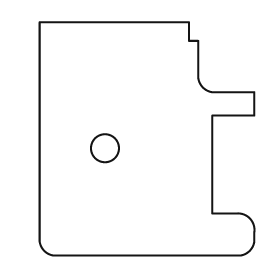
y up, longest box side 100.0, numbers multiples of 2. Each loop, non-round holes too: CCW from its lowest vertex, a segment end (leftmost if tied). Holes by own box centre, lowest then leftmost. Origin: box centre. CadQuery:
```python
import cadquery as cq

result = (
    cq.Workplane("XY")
    .moveTo(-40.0, -50.0)
    .lineTo(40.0, -50.0)
    .threePointArc((44.0, -48.0), (46.0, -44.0))
    .lineTo(46.0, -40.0)
    .threePointArc((44.0, -34.0), (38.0, -32.0))
    .lineTo(28.0, -32.0)
    .lineTo(28.0, 10.0)
    .lineTo(46.0, 10.0)
    .lineTo(46.0, 20.0)
    .lineTo(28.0, 20.0)
    .threePointArc((24.0, 22.0), (22.0, 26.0))
    .lineTo(22.0, 42.0)
    .lineTo(18.0, 42.0)
    .lineTo(18.0, 50.0)
    .lineTo(-46.0, 50.0)
    .lineTo(-46.0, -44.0)
    .threePointArc((-44.0, -48.0), (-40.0, -50.0))
    .close()
    .moveTo(-18.0, -4.0)
    .circle(6.0)
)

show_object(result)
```